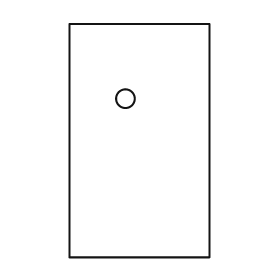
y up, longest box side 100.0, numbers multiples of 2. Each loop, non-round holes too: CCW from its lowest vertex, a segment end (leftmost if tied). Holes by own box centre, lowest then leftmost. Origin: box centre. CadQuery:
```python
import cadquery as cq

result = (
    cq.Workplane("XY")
    .moveTo(-30.0, -50.0)
    .lineTo(30.0, -50.0)
    .lineTo(30.0, 50.0)
    .lineTo(-30.0, 50.0)
    .close()
    .moveTo(-6.0, 18.0)
    .circle(4.0)
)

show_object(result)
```